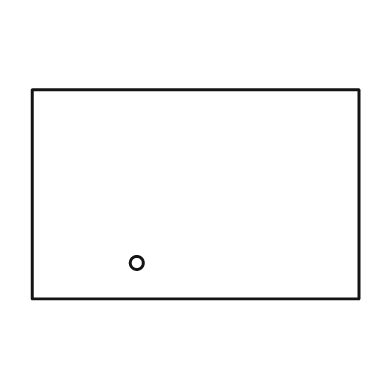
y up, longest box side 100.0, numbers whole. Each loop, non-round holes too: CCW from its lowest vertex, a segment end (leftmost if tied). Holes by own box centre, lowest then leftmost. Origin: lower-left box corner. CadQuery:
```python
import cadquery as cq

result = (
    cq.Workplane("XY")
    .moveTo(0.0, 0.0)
    .lineTo(100.0, 0.0)
    .lineTo(100.0, 64.0)
    .lineTo(0.0, 64.0)
    .close()
    .moveTo(32.0, 11.0)
    .circle(2.0)
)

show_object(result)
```